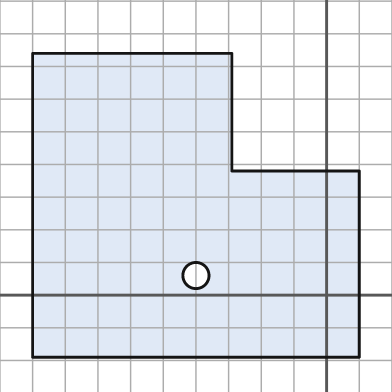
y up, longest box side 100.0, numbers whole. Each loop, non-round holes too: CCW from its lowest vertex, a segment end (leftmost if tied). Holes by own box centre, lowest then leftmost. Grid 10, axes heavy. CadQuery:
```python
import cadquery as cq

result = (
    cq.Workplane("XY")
    .moveTo(-90.0, -19.0)
    .lineTo(10.0, -19.0)
    .lineTo(10.0, 38.0)
    .lineTo(-29.0, 38.0)
    .lineTo(-29.0, 74.0)
    .lineTo(-90.0, 74.0)
    .close()
    .moveTo(-40.0, 6.0)
    .circle(4.0)
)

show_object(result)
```